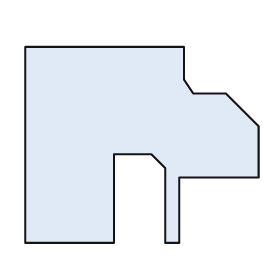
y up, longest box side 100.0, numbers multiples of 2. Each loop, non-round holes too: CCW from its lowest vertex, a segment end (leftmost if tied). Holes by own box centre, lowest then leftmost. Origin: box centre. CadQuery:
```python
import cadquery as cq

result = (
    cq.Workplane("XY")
    .moveTo(-50.0, -42.0)
    .lineTo(-12.0, -42.0)
    .lineTo(-12.0, -4.0)
    .lineTo(4.0, -4.0)
    .lineTo(10.0, -10.0)
    .lineTo(10.0, -42.0)
    .lineTo(16.0, -42.0)
    .lineTo(16.0, -14.0)
    .lineTo(50.0, -14.0)
    .lineTo(50.0, 8.0)
    .lineTo(36.0, 22.0)
    .lineTo(22.0, 22.0)
    .lineTo(18.0, 28.0)
    .lineTo(18.0, 42.0)
    .lineTo(-50.0, 42.0)
    .close()
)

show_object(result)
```